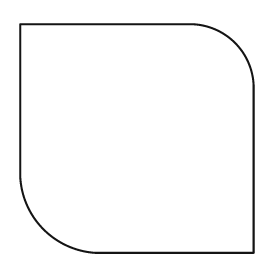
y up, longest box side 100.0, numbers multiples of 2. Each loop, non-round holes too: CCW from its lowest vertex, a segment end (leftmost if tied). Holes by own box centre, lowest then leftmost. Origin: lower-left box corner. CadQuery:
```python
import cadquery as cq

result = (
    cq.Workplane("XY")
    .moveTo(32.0, 0.0)
    .lineTo(100.0, 0.0)
    .lineTo(100.0, 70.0)
    .threePointArc((92.0, 90.0), (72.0, 98.0))
    .lineTo(0.0, 98.0)
    .lineTo(0.0, 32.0)
    .threePointArc((10.0, 10.0), (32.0, 0.0))
    .close()
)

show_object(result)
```